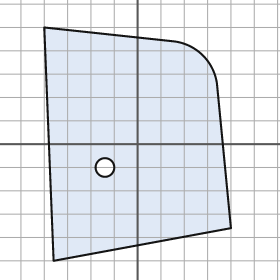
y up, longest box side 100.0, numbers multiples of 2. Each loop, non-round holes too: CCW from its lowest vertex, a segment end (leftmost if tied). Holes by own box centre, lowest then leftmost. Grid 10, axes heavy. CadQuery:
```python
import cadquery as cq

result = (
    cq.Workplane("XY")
    .moveTo(-36.0, -50.0)
    .lineTo(40.0, -36.0)
    .lineTo(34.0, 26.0)
    .threePointArc((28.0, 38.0), (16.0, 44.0))
    .lineTo(-40.0, 50.0)
    .close()
    .moveTo(-14.0, -10.0)
    .circle(4.0)
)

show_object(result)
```